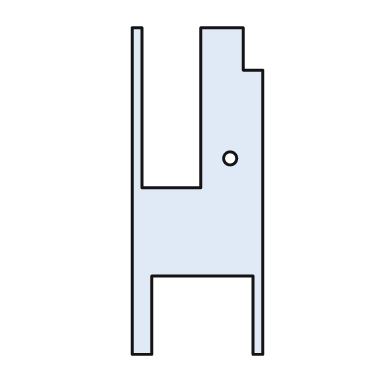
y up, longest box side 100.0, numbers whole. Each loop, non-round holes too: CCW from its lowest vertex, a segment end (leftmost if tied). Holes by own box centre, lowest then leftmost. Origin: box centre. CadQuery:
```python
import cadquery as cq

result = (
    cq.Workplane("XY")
    .moveTo(-20.0, -50.0)
    .lineTo(-14.0, -50.0)
    .lineTo(-14.0, -26.0)
    .lineTo(17.0, -26.0)
    .lineTo(17.0, -50.0)
    .lineTo(20.0, -50.0)
    .lineTo(20.0, 37.0)
    .lineTo(14.0, 37.0)
    .lineTo(14.0, 50.0)
    .lineTo(1.0, 50.0)
    .lineTo(1.0, 1.0)
    .lineTo(-17.0, 1.0)
    .lineTo(-17.0, 50.0)
    .lineTo(-20.0, 50.0)
    .close()
    .moveTo(10.0, 10.0)
    .circle(2.0)
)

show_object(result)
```